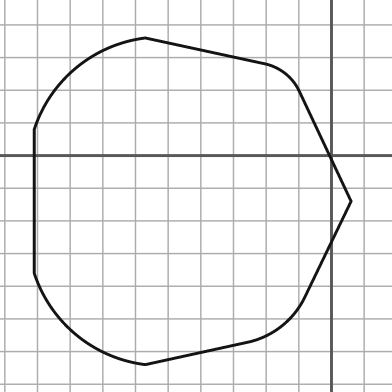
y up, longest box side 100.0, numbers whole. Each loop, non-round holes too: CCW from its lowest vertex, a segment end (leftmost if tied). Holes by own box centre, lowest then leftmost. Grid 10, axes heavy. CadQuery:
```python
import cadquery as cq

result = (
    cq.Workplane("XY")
    .moveTo(-57.0, -64.0)
    .lineTo(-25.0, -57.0)
    .threePointArc((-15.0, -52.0), (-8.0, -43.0))
    .lineTo(6.0, -14.0)
    .lineTo(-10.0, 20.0)
    .threePointArc((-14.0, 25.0), (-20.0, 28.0))
    .lineTo(-57.0, 36.0)
    .threePointArc((-78.0, 27.0), (-91.0, 8.0))
    .lineTo(-91.0, -36.0)
    .threePointArc((-78.0, -55.0), (-57.0, -64.0))
    .close()
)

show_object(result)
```